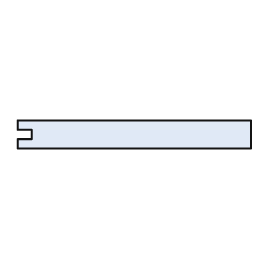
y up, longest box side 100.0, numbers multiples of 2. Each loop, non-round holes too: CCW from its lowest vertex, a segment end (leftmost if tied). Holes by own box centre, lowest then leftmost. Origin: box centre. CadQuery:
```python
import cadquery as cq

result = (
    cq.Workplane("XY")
    .moveTo(-50.0, -6.0)
    .lineTo(50.0, -6.0)
    .lineTo(50.0, 6.0)
    .lineTo(-50.0, 6.0)
    .lineTo(-50.0, 2.0)
    .lineTo(-44.0, 2.0)
    .lineTo(-44.0, -2.0)
    .lineTo(-50.0, -2.0)
    .close()
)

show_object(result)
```